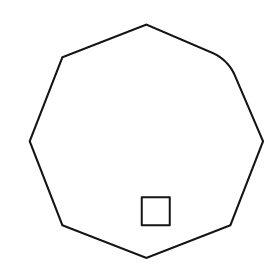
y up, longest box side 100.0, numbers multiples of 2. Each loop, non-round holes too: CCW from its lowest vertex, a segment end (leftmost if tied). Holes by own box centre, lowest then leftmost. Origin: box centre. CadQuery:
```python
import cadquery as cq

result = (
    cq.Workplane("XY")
    .moveTo(0.0, -50.0)
    .lineTo(36.0, -36.0)
    .lineTo(50.0, 0.0)
    .lineTo(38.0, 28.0)
    .threePointArc((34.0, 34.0), (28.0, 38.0))
    .lineTo(0.0, 50.0)
    .lineTo(-36.0, 36.0)
    .lineTo(-50.0, 0.0)
    .lineTo(-36.0, -36.0)
    .close()
    .moveTo(-2.0, -36.0)
    .lineTo(10.0, -36.0)
    .lineTo(10.0, -24.0)
    .lineTo(-2.0, -24.0)
    .close()
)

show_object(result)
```